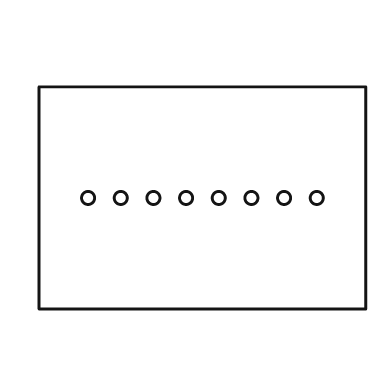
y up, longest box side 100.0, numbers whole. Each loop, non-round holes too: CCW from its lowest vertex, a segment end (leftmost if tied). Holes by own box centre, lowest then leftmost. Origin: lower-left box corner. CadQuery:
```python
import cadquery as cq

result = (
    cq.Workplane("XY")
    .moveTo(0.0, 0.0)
    .lineTo(100.0, 0.0)
    .lineTo(100.0, 68.0)
    .lineTo(0.0, 68.0)
    .close()
    .moveTo(15.0, 34.0)
    .circle(2.0)
    .moveTo(25.0, 34.0)
    .circle(2.0)
    .moveTo(35.0, 34.0)
    .circle(2.0)
    .moveTo(45.0, 34.0)
    .circle(2.0)
    .moveTo(55.0, 34.0)
    .circle(2.0)
    .moveTo(65.0, 34.0)
    .circle(2.0)
    .moveTo(75.0, 34.0)
    .circle(2.0)
    .moveTo(85.0, 34.0)
    .circle(2.0)
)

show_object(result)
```